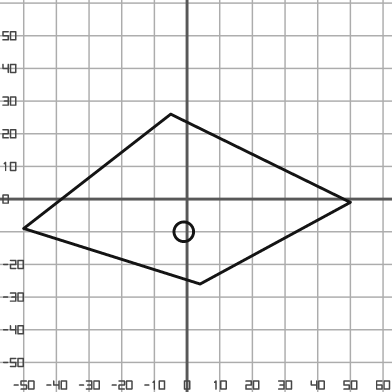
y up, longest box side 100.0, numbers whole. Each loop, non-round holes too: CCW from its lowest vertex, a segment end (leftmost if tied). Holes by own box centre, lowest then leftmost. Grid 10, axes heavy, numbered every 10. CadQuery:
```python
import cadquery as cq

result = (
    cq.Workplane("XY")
    .moveTo(4.0, -26.0)
    .lineTo(50.0, -1.0)
    .lineTo(-5.0, 26.0)
    .lineTo(-50.0, -9.0)
    .close()
    .moveTo(-1.0, -10.0)
    .circle(3.0)
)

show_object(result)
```